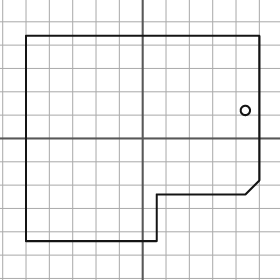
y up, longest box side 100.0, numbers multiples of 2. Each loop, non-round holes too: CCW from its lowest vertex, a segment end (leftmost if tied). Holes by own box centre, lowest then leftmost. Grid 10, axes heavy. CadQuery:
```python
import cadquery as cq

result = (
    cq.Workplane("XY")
    .moveTo(-50.0, -44.0)
    .lineTo(6.0, -44.0)
    .lineTo(6.0, -24.0)
    .lineTo(44.0, -24.0)
    .lineTo(50.0, -18.0)
    .lineTo(50.0, 44.0)
    .lineTo(-50.0, 44.0)
    .close()
    .moveTo(44.0, 12.0)
    .circle(2.0)
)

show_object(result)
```